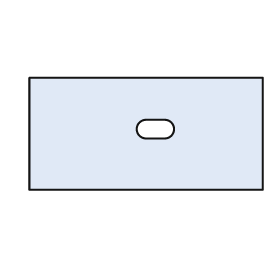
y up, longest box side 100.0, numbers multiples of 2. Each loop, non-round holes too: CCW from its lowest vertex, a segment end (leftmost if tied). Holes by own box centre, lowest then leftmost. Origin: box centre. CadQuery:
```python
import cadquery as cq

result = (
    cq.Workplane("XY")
    .moveTo(-50.0, -24.0)
    .lineTo(50.0, -24.0)
    .lineTo(50.0, 24.0)
    .lineTo(-50.0, 24.0)
    .close()
    .moveTo(0.0, -2.0)
    .lineTo(8.0, -2.0)
    .threePointArc((12.0, 2.0), (8.0, 6.0))
    .lineTo(0.0, 6.0)
    .threePointArc((-4.0, 2.0), (0.0, -2.0))
    .close()
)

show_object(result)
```